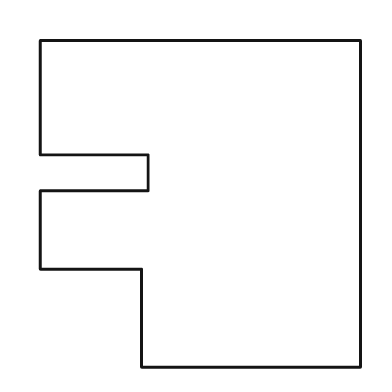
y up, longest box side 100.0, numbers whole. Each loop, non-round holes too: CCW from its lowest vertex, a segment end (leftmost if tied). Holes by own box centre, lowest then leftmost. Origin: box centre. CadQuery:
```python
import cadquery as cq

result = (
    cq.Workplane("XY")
    .moveTo(-18.0, -50.0)
    .lineTo(49.0, -50.0)
    .lineTo(49.0, 50.0)
    .lineTo(-49.0, 50.0)
    .lineTo(-49.0, 15.0)
    .lineTo(-16.0, 15.0)
    .lineTo(-16.0, 4.0)
    .lineTo(-49.0, 4.0)
    .lineTo(-49.0, -20.0)
    .lineTo(-18.0, -20.0)
    .close()
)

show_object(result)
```